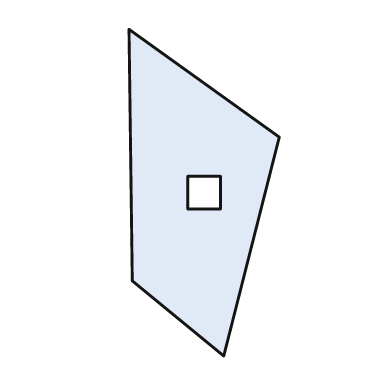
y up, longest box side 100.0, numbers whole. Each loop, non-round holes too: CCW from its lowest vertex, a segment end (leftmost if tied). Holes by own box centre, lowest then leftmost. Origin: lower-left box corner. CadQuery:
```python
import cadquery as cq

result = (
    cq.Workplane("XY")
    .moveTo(29.0, 0.0)
    .lineTo(46.0, 67.0)
    .lineTo(0.0, 100.0)
    .lineTo(1.0, 23.0)
    .close()
    .moveTo(18.0, 45.0)
    .lineTo(28.0, 45.0)
    .lineTo(28.0, 55.0)
    .lineTo(18.0, 55.0)
    .close()
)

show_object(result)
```